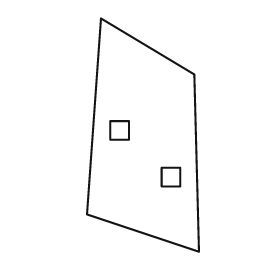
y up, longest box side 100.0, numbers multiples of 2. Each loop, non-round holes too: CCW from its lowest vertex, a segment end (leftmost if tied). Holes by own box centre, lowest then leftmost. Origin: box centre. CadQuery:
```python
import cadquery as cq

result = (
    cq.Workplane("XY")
    .moveTo(24.0, -50.0)
    .lineTo(22.0, 26.0)
    .lineTo(-18.0, 50.0)
    .lineTo(-24.0, -34.0)
    .close()
    .moveTo(8.0, -22.0)
    .lineTo(16.0, -22.0)
    .lineTo(16.0, -14.0)
    .lineTo(8.0, -14.0)
    .close()
    .moveTo(-14.0, -2.0)
    .lineTo(-6.0, -2.0)
    .lineTo(-6.0, 6.0)
    .lineTo(-14.0, 6.0)
    .close()
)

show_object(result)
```